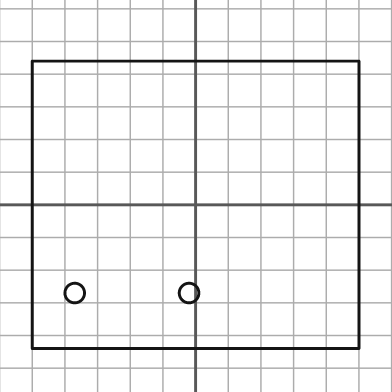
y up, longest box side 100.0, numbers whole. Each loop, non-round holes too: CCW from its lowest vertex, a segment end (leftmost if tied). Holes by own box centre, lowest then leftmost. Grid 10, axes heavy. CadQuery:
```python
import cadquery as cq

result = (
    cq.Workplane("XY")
    .moveTo(-50.0, -44.0)
    .lineTo(50.0, -44.0)
    .lineTo(50.0, 44.0)
    .lineTo(-50.0, 44.0)
    .close()
    .moveTo(-37.0, -27.0)
    .circle(3.0)
    .moveTo(-2.0, -27.0)
    .circle(3.0)
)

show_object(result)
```